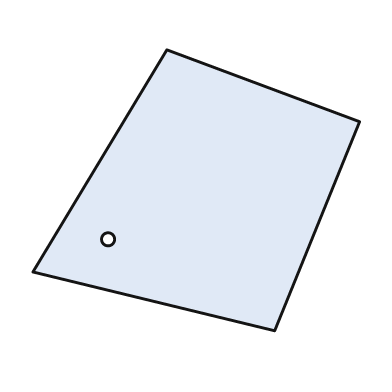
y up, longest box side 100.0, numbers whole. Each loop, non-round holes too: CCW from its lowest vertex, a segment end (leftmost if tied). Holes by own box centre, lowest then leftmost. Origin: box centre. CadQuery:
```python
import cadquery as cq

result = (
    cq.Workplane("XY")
    .moveTo(24.0, -43.0)
    .lineTo(50.0, 21.0)
    .lineTo(-9.0, 43.0)
    .lineTo(-50.0, -25.0)
    .close()
    .moveTo(-27.0, -15.0)
    .circle(2.0)
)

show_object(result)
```